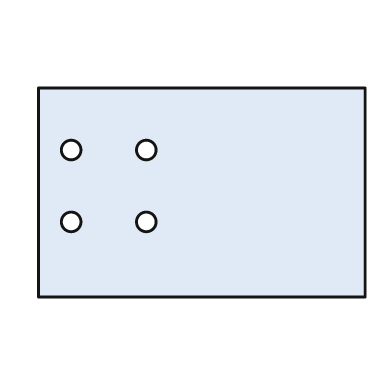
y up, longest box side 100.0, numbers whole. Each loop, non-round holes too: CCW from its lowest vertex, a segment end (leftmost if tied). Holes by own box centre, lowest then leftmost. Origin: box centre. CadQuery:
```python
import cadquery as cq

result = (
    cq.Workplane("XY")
    .moveTo(-50.0, -32.0)
    .lineTo(50.0, -32.0)
    .lineTo(50.0, 32.0)
    .lineTo(-50.0, 32.0)
    .close()
    .moveTo(-40.0, -9.0)
    .circle(3.0)
    .moveTo(-17.0, -9.0)
    .circle(3.0)
    .moveTo(-40.0, 13.0)
    .circle(3.0)
    .moveTo(-17.0, 13.0)
    .circle(3.0)
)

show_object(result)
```